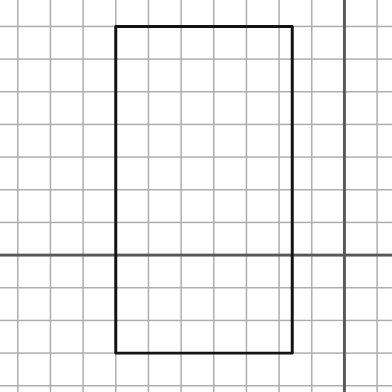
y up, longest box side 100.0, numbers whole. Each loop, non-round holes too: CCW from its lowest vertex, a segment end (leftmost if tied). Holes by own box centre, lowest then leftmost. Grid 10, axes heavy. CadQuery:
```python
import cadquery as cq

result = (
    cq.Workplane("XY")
    .moveTo(-70.0, -30.0)
    .lineTo(-16.0, -30.0)
    .lineTo(-16.0, 70.0)
    .lineTo(-70.0, 70.0)
    .close()
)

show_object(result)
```